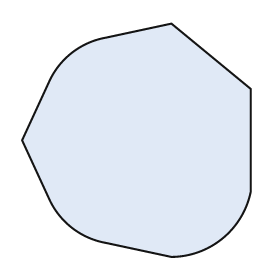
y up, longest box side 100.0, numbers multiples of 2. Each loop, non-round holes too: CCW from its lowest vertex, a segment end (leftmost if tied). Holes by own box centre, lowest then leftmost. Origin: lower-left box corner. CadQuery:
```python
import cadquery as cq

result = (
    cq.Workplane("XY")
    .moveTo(64.0, 0.0)
    .threePointArc((86.0, 8.0), (98.0, 28.0))
    .lineTo(98.0, 72.0)
    .lineTo(64.0, 100.0)
    .lineTo(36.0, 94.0)
    .threePointArc((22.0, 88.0), (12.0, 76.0))
    .lineTo(0.0, 50.0)
    .lineTo(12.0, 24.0)
    .threePointArc((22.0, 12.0), (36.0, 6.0))
    .close()
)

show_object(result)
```